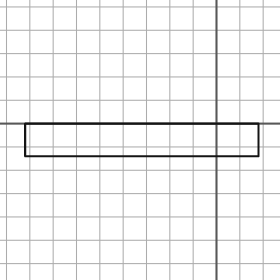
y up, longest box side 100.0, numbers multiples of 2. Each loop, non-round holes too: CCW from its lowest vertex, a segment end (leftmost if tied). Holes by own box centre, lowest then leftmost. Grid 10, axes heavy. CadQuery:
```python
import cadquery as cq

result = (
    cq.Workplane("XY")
    .moveTo(-82.0, -14.0)
    .lineTo(18.0, -14.0)
    .lineTo(18.0, 0.0)
    .lineTo(-82.0, 0.0)
    .close()
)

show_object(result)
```